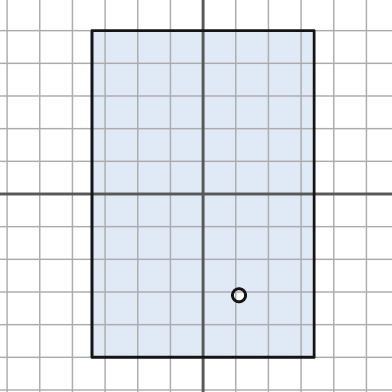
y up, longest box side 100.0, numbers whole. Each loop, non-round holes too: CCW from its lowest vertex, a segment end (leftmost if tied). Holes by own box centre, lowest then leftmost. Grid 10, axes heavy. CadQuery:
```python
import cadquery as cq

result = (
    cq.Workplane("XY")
    .moveTo(-34.0, -50.0)
    .lineTo(34.0, -50.0)
    .lineTo(34.0, 50.0)
    .lineTo(-34.0, 50.0)
    .close()
    .moveTo(11.0, -31.0)
    .circle(2.0)
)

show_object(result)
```